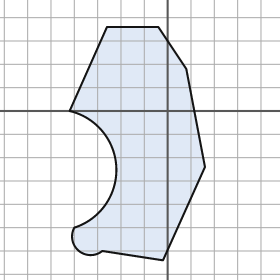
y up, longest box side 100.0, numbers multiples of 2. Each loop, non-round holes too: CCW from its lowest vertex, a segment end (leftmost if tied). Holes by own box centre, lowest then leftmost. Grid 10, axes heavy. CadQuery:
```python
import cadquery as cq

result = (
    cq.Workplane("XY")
    .moveTo(-2.0, -64.0)
    .lineTo(16.0, -24.0)
    .lineTo(8.0, 18.0)
    .lineTo(-4.0, 36.0)
    .lineTo(-26.0, 36.0)
    .lineTo(-42.0, 0.0)
    .threePointArc((-22.0, -24.0), (-40.0, -50.0))
    .threePointArc((-38.0, -60.0), (-28.0, -60.0))
    .close()
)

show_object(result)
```